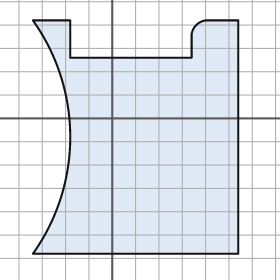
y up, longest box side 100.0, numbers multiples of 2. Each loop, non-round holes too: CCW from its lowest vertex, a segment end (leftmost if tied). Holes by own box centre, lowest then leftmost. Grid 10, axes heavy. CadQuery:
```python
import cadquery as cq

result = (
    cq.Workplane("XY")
    .moveTo(-34.0, -58.0)
    .lineTo(54.0, -58.0)
    .lineTo(54.0, 42.0)
    .lineTo(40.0, 42.0)
    .threePointArc((36.0, 40.0), (34.0, 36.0))
    .lineTo(34.0, 26.0)
    .lineTo(-18.0, 26.0)
    .lineTo(-18.0, 42.0)
    .lineTo(-34.0, 42.0)
    .threePointArc((-18.0, -8.0), (-34.0, -58.0))
    .close()
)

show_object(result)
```